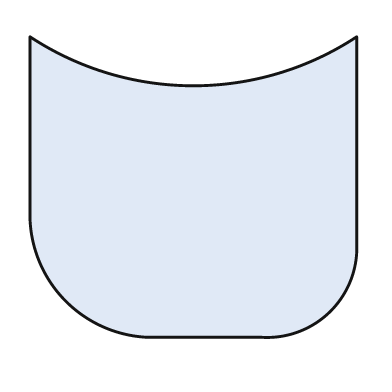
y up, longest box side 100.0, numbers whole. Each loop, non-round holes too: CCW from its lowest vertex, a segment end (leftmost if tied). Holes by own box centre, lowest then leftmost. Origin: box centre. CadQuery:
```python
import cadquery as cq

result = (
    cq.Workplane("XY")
    .moveTo(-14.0, -46.0)
    .lineTo(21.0, -46.0)
    .threePointArc((42.0, -38.0), (50.0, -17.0))
    .lineTo(50.0, 46.0)
    .threePointArc((0.0, 31.0), (-50.0, 46.0))
    .lineTo(-50.0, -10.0)
    .threePointArc((-39.0, -35.0), (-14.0, -46.0))
    .close()
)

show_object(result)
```